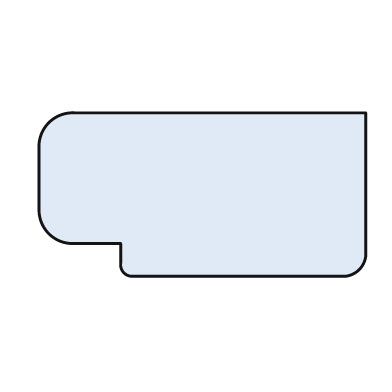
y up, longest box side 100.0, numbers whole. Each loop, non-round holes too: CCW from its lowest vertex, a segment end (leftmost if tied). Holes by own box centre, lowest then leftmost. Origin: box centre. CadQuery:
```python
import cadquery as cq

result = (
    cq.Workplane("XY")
    .moveTo(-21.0, -25.0)
    .lineTo(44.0, -25.0)
    .threePointArc((48.0, -23.0), (50.0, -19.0))
    .lineTo(50.0, 25.0)
    .lineTo(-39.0, 25.0)
    .threePointArc((-47.0, 22.0), (-50.0, 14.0))
    .lineTo(-50.0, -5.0)
    .threePointArc((-47.0, -12.0), (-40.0, -15.0))
    .lineTo(-25.0, -15.0)
    .lineTo(-25.0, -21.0)
    .threePointArc((-24.0, -24.0), (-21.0, -25.0))
    .close()
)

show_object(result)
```